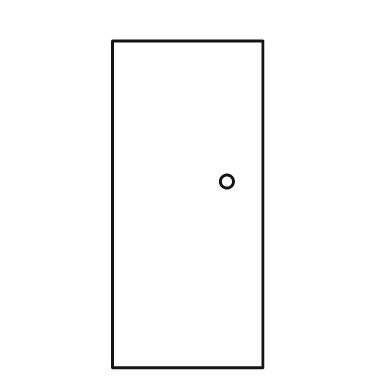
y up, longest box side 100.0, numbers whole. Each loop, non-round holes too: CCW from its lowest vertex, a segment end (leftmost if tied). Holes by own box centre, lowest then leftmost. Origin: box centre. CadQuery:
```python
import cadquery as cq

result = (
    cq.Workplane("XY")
    .moveTo(-23.0, -50.0)
    .lineTo(23.0, -50.0)
    .lineTo(23.0, 50.0)
    .lineTo(-23.0, 50.0)
    .close()
    .moveTo(12.0, 7.0)
    .circle(2.0)
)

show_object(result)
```